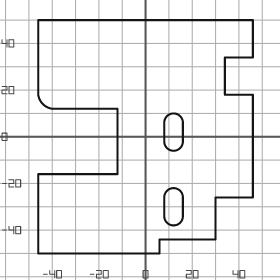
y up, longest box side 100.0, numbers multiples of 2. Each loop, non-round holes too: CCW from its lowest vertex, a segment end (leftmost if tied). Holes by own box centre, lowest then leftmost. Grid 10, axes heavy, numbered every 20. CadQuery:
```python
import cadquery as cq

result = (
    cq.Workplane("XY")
    .moveTo(-46.0, -50.0)
    .lineTo(6.0, -50.0)
    .lineTo(6.0, -44.0)
    .lineTo(30.0, -44.0)
    .lineTo(30.0, -26.0)
    .lineTo(46.0, -26.0)
    .lineTo(46.0, 18.0)
    .lineTo(34.0, 18.0)
    .lineTo(34.0, 34.0)
    .lineTo(46.0, 34.0)
    .lineTo(46.0, 50.0)
    .lineTo(-46.0, 50.0)
    .lineTo(-46.0, 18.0)
    .threePointArc((-44.0, 14.0), (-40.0, 12.0))
    .lineTo(-12.0, 12.0)
    .lineTo(-12.0, -16.0)
    .lineTo(-46.0, -16.0)
    .close()
    .moveTo(8.0, -34.0)
    .threePointArc((12.0, -38.0), (16.0, -34.0))
    .lineTo(16.0, -26.0)
    .threePointArc((12.0, -22.0), (8.0, -26.0))
    .close()
    .moveTo(8.0, -2.0)
    .threePointArc((12.0, -6.0), (16.0, -2.0))
    .lineTo(16.0, 6.0)
    .threePointArc((12.0, 10.0), (8.0, 6.0))
    .close()
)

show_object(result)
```